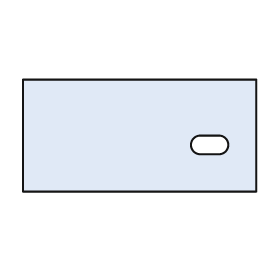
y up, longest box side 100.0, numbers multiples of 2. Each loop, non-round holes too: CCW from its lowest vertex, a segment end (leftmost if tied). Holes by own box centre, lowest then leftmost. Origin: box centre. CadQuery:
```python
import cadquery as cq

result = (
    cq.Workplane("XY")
    .moveTo(-50.0, -24.0)
    .lineTo(50.0, -24.0)
    .lineTo(50.0, 24.0)
    .lineTo(-50.0, 24.0)
    .close()
    .moveTo(26.0, -8.0)
    .lineTo(34.0, -8.0)
    .threePointArc((38.0, -4.0), (34.0, 0.0))
    .lineTo(26.0, 0.0)
    .threePointArc((22.0, -4.0), (26.0, -8.0))
    .close()
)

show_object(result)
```